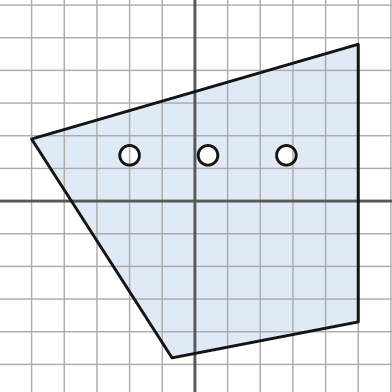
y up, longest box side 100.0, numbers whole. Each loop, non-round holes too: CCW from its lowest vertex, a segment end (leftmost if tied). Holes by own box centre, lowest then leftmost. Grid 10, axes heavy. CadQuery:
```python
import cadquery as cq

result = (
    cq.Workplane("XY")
    .moveTo(-7.0, -48.0)
    .lineTo(50.0, -37.0)
    .lineTo(50.0, 48.0)
    .lineTo(-50.0, 19.0)
    .close()
    .moveTo(-20.0, 14.0)
    .circle(3.0)
    .moveTo(4.0, 14.0)
    .circle(3.0)
    .moveTo(28.0, 14.0)
    .circle(3.0)
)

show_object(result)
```